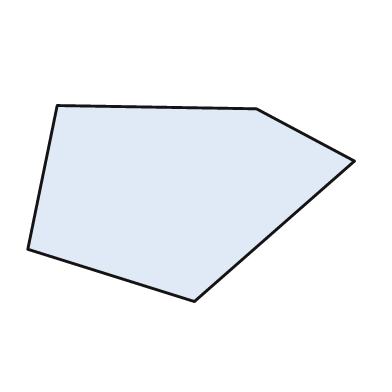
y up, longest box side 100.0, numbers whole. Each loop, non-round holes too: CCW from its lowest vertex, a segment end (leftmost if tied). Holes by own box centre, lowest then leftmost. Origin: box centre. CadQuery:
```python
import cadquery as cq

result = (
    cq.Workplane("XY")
    .moveTo(1.0, -30.0)
    .lineTo(50.0, 13.0)
    .lineTo(20.0, 29.0)
    .lineTo(-41.0, 30.0)
    .lineTo(-50.0, -14.0)
    .close()
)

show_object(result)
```